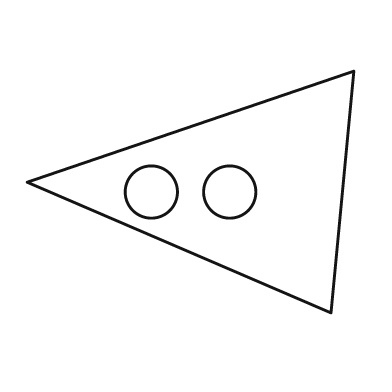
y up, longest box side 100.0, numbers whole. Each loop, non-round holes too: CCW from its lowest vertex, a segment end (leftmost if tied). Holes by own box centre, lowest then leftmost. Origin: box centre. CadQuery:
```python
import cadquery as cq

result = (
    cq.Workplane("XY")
    .moveTo(43.0, -37.0)
    .lineTo(50.0, 37.0)
    .lineTo(-50.0, 3.0)
    .close()
    .moveTo(-12.0, 0.0)
    .circle(8.0)
    .moveTo(12.0, 0.0)
    .circle(8.0)
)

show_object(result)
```